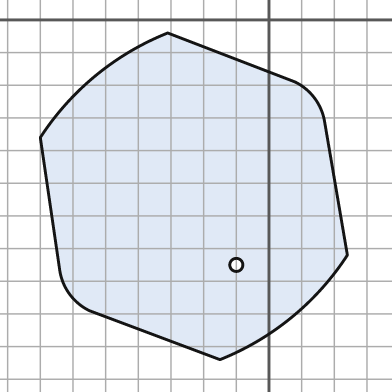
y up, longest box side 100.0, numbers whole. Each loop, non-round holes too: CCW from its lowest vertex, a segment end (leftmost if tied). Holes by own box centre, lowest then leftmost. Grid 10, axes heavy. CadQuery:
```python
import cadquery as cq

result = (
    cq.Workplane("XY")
    .moveTo(-15.0, -104.0)
    .threePointArc((7.0, -91.0), (24.0, -72.0))
    .lineTo(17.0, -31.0)
    .threePointArc((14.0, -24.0), (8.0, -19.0))
    .lineTo(-31.0, -4.0)
    .threePointArc((-53.0, -17.0), (-70.0, -36.0))
    .lineTo(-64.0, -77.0)
    .threePointArc((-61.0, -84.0), (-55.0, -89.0))
    .close()
    .moveTo(-10.0, -75.0)
    .circle(2.0)
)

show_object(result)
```